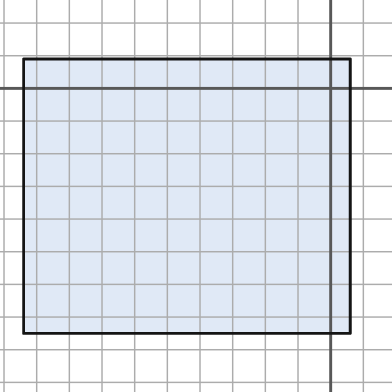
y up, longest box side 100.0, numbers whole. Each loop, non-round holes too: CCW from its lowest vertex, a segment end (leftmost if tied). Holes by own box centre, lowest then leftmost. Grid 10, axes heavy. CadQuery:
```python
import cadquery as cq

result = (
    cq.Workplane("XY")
    .moveTo(-94.0, -75.0)
    .lineTo(6.0, -75.0)
    .lineTo(6.0, 9.0)
    .lineTo(-94.0, 9.0)
    .close()
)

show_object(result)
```